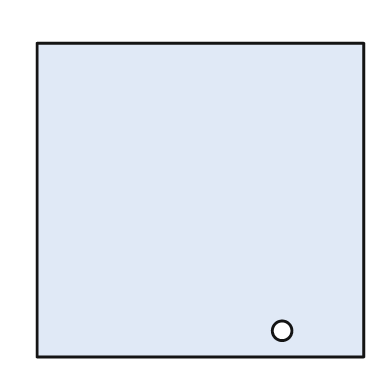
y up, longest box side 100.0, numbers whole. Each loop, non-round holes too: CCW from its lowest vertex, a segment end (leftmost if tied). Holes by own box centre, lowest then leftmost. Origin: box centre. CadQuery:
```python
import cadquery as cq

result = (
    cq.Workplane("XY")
    .moveTo(-50.0, -48.0)
    .lineTo(50.0, -48.0)
    .lineTo(50.0, 48.0)
    .lineTo(-50.0, 48.0)
    .close()
    .moveTo(25.0, -40.0)
    .circle(3.0)
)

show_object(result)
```